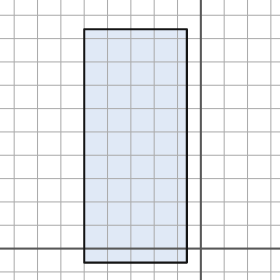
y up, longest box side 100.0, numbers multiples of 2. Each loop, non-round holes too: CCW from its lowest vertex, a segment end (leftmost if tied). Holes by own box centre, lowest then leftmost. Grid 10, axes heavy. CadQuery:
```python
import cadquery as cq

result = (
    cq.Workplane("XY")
    .moveTo(-50.0, -6.0)
    .lineTo(-6.0, -6.0)
    .lineTo(-6.0, 94.0)
    .lineTo(-50.0, 94.0)
    .close()
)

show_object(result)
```